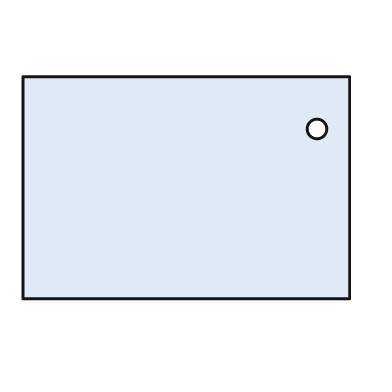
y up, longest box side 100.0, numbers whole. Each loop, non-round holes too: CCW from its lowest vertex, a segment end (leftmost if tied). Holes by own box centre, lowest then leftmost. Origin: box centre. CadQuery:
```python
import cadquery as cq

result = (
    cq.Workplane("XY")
    .moveTo(-50.0, -34.0)
    .lineTo(50.0, -34.0)
    .lineTo(50.0, 34.0)
    .lineTo(-50.0, 34.0)
    .close()
    .moveTo(40.0, 18.0)
    .circle(3.0)
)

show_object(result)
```